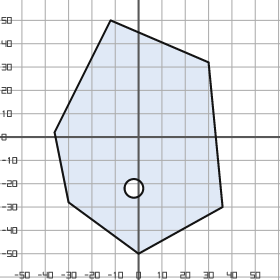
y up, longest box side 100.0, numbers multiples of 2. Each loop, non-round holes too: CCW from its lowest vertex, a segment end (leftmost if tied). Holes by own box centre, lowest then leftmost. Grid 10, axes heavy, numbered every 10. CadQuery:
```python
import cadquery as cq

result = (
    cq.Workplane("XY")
    .moveTo(0.0, -50.0)
    .lineTo(36.0, -30.0)
    .lineTo(30.0, 32.0)
    .lineTo(-12.0, 50.0)
    .lineTo(-36.0, 2.0)
    .lineTo(-30.0, -28.0)
    .close()
    .moveTo(-2.0, -22.0)
    .circle(4.0)
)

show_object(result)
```